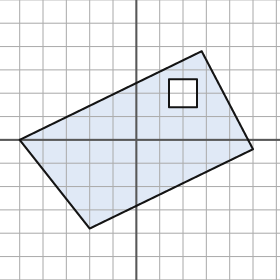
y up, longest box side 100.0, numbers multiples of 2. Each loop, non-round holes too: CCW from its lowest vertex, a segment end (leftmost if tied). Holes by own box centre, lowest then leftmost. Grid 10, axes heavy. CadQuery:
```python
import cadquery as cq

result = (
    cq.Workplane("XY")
    .moveTo(-20.0, -38.0)
    .lineTo(50.0, -4.0)
    .lineTo(28.0, 38.0)
    .lineTo(-50.0, 0.0)
    .close()
    .moveTo(14.0, 14.0)
    .lineTo(26.0, 14.0)
    .lineTo(26.0, 26.0)
    .lineTo(14.0, 26.0)
    .close()
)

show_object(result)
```